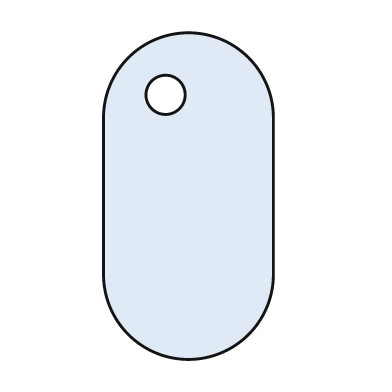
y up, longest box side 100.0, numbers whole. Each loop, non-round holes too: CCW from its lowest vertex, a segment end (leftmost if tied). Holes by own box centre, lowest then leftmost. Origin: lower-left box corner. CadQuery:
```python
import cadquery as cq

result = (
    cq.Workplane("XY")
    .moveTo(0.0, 26.0)
    .threePointArc((26.0, 0.0), (52.0, 26.0))
    .lineTo(52.0, 74.0)
    .threePointArc((26.0, 100.0), (0.0, 74.0))
    .close()
    .moveTo(19.0, 81.0)
    .circle(6.0)
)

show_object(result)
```